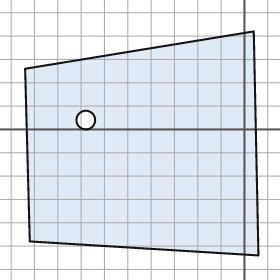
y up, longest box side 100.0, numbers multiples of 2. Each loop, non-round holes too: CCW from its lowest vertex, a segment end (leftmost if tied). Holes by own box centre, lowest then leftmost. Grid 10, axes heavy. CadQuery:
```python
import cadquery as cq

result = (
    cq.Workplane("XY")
    .moveTo(6.0, -54.0)
    .lineTo(4.0, 42.0)
    .lineTo(-94.0, 26.0)
    .lineTo(-92.0, -48.0)
    .close()
    .moveTo(-68.0, 4.0)
    .circle(4.0)
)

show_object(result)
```